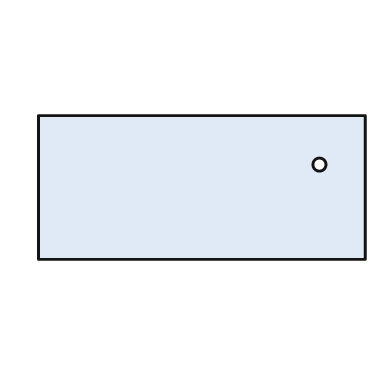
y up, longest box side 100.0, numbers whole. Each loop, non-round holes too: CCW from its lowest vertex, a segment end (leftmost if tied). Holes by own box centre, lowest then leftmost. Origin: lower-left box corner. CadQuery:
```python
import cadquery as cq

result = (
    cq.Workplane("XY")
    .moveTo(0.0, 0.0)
    .lineTo(100.0, 0.0)
    .lineTo(100.0, 44.0)
    .lineTo(0.0, 44.0)
    .close()
    .moveTo(86.0, 29.0)
    .circle(2.0)
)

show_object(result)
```